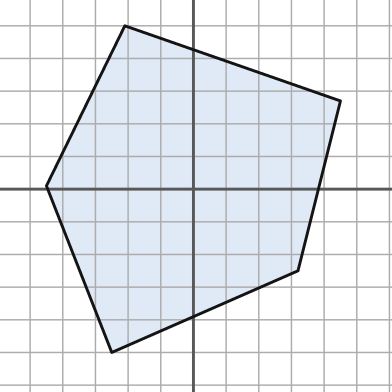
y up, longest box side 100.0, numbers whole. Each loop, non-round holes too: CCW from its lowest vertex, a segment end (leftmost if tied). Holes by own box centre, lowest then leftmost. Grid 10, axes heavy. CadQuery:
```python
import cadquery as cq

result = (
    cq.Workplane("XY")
    .moveTo(-25.0, -50.0)
    .lineTo(32.0, -25.0)
    .lineTo(45.0, 27.0)
    .lineTo(-21.0, 50.0)
    .lineTo(-45.0, 1.0)
    .close()
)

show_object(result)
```